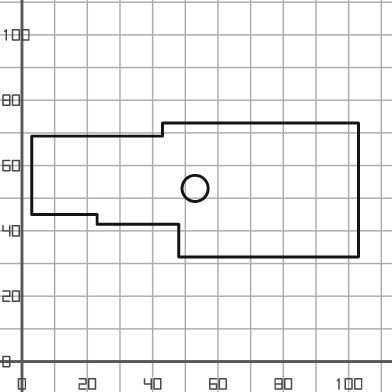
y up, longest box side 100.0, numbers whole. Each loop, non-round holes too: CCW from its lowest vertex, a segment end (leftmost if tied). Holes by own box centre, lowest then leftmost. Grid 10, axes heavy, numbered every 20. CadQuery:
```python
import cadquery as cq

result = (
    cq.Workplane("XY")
    .moveTo(48.0, 32.0)
    .lineTo(103.0, 32.0)
    .lineTo(103.0, 73.0)
    .lineTo(43.0, 73.0)
    .lineTo(43.0, 69.0)
    .lineTo(3.0, 69.0)
    .lineTo(3.0, 45.0)
    .lineTo(23.0, 45.0)
    .lineTo(23.0, 42.0)
    .lineTo(48.0, 42.0)
    .close()
    .moveTo(53.0, 53.0)
    .circle(4.0)
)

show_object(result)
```